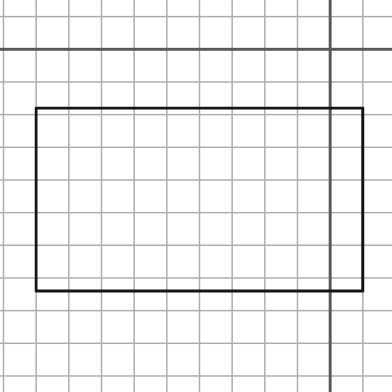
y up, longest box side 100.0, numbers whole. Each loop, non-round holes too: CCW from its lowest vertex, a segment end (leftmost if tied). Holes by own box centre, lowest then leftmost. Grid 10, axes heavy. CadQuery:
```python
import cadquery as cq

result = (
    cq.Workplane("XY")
    .moveTo(-90.0, -74.0)
    .lineTo(10.0, -74.0)
    .lineTo(10.0, -18.0)
    .lineTo(-90.0, -18.0)
    .close()
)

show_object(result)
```